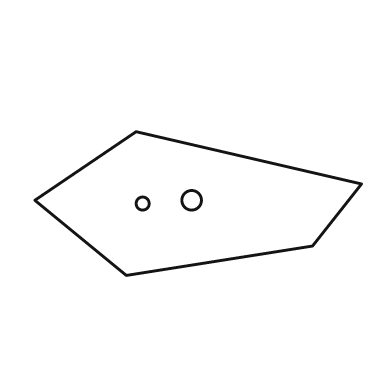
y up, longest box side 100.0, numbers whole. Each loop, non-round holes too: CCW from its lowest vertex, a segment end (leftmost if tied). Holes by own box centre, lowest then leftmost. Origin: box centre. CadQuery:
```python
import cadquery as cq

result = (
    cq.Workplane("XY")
    .moveTo(-22.0, -22.0)
    .lineTo(35.0, -13.0)
    .lineTo(50.0, 6.0)
    .lineTo(-19.0, 22.0)
    .lineTo(-50.0, 1.0)
    .close()
    .moveTo(-17.0, 0.0)
    .circle(2.0)
    .moveTo(-2.0, 1.0)
    .circle(3.0)
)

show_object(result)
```